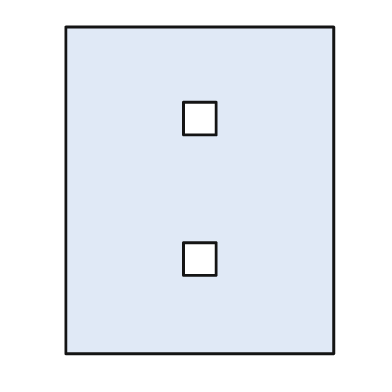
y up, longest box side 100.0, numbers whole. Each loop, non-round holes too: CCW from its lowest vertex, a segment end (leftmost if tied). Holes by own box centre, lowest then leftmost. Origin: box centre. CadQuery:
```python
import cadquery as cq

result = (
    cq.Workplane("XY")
    .moveTo(-41.0, -50.0)
    .lineTo(41.0, -50.0)
    .lineTo(41.0, 50.0)
    .lineTo(-41.0, 50.0)
    .close()
    .moveTo(-5.0, -26.0)
    .lineTo(5.0, -26.0)
    .lineTo(5.0, -16.0)
    .lineTo(-5.0, -16.0)
    .close()
    .moveTo(-5.0, 17.0)
    .lineTo(5.0, 17.0)
    .lineTo(5.0, 27.0)
    .lineTo(-5.0, 27.0)
    .close()
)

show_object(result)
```